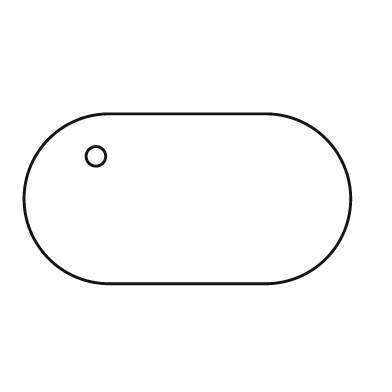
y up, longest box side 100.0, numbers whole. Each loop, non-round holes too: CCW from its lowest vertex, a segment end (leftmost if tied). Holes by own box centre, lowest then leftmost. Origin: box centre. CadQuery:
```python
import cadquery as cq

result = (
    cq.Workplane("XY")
    .moveTo(-24.0, -26.0)
    .lineTo(24.0, -26.0)
    .threePointArc((50.0, 0.0), (24.0, 26.0))
    .lineTo(-24.0, 26.0)
    .threePointArc((-50.0, 0.0), (-24.0, -26.0))
    .close()
    .moveTo(-28.0, 13.0)
    .circle(3.0)
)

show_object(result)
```